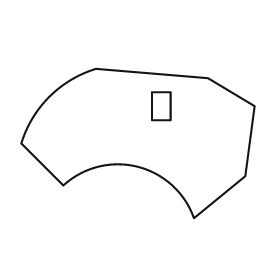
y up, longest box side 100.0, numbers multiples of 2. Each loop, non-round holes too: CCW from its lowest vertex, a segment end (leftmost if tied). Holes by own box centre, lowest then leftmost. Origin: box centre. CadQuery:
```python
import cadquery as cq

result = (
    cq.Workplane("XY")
    .moveTo(24.0, -32.0)
    .lineTo(46.0, -14.0)
    .lineTo(50.0, 16.0)
    .lineTo(30.0, 28.0)
    .lineTo(-18.0, 32.0)
    .threePointArc((-38.0, 20.0), (-50.0, 0.0))
    .lineTo(-32.0, -18.0)
    .threePointArc((0.0, -10.0), (24.0, -32.0))
    .close()
    .moveTo(6.0, 10.0)
    .lineTo(14.0, 10.0)
    .lineTo(14.0, 22.0)
    .lineTo(6.0, 22.0)
    .close()
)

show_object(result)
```